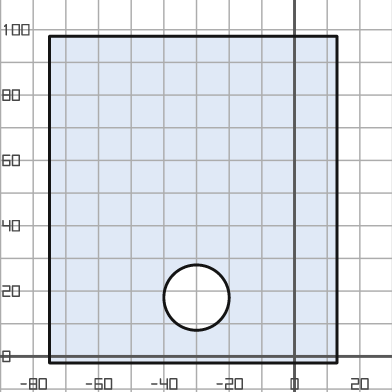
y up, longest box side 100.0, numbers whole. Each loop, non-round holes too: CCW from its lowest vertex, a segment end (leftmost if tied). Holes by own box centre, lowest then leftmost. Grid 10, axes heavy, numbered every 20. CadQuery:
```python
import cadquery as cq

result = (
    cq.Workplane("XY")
    .moveTo(-75.0, -2.0)
    .lineTo(13.0, -2.0)
    .lineTo(13.0, 98.0)
    .lineTo(-75.0, 98.0)
    .close()
    .moveTo(-30.0, 18.0)
    .circle(10.0)
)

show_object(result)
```